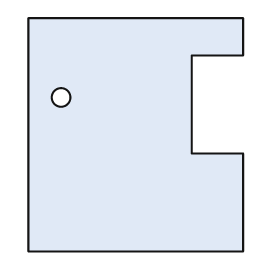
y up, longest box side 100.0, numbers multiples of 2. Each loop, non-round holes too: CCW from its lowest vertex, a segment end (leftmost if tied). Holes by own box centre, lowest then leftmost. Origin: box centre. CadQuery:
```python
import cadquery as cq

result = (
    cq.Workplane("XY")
    .moveTo(-46.0, -50.0)
    .lineTo(46.0, -50.0)
    .lineTo(46.0, -8.0)
    .lineTo(24.0, -8.0)
    .lineTo(24.0, 34.0)
    .lineTo(46.0, 34.0)
    .lineTo(46.0, 50.0)
    .lineTo(-46.0, 50.0)
    .close()
    .moveTo(-32.0, 16.0)
    .circle(4.0)
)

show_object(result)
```